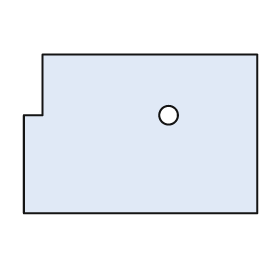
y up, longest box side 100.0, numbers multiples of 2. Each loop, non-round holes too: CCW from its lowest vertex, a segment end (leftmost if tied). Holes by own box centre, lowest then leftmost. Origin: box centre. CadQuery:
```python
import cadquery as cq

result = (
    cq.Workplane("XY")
    .moveTo(-50.0, -34.0)
    .lineTo(50.0, -34.0)
    .lineTo(50.0, 34.0)
    .lineTo(-42.0, 34.0)
    .lineTo(-42.0, 8.0)
    .lineTo(-50.0, 8.0)
    .close()
    .moveTo(12.0, 8.0)
    .circle(4.0)
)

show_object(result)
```